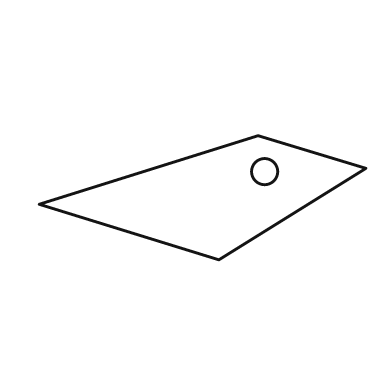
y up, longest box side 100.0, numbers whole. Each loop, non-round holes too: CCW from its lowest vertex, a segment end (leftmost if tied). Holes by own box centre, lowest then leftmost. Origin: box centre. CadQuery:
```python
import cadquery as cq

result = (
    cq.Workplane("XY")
    .moveTo(5.0, -19.0)
    .lineTo(50.0, 9.0)
    .lineTo(17.0, 19.0)
    .lineTo(-50.0, -2.0)
    .close()
    .moveTo(19.0, 8.0)
    .circle(4.0)
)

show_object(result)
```